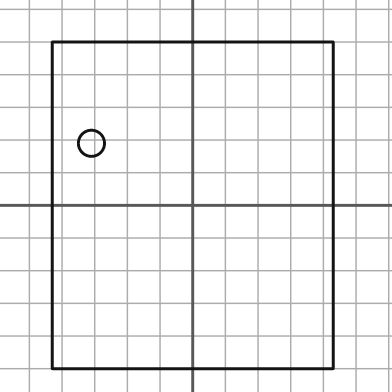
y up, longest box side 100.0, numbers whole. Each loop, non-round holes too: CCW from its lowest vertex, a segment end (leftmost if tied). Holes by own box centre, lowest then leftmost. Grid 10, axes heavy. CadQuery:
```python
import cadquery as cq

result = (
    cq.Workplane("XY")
    .moveTo(-43.0, -50.0)
    .lineTo(43.0, -50.0)
    .lineTo(43.0, 50.0)
    .lineTo(-43.0, 50.0)
    .close()
    .moveTo(-31.0, 19.0)
    .circle(4.0)
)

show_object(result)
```